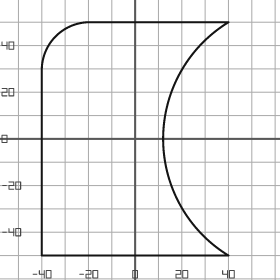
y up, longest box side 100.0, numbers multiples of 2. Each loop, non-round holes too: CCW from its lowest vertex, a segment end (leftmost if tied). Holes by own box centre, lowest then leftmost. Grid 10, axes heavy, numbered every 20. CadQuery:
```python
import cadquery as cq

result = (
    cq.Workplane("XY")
    .moveTo(-40.0, -50.0)
    .lineTo(40.0, -50.0)
    .threePointArc((12.0, 0.0), (40.0, 50.0))
    .lineTo(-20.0, 50.0)
    .threePointArc((-34.0, 44.0), (-40.0, 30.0))
    .close()
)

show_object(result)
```